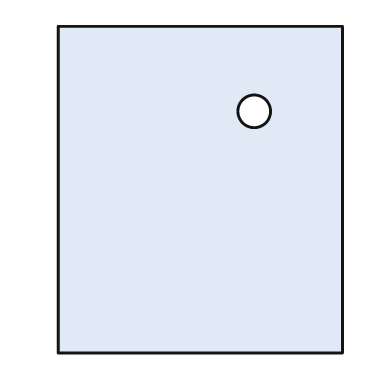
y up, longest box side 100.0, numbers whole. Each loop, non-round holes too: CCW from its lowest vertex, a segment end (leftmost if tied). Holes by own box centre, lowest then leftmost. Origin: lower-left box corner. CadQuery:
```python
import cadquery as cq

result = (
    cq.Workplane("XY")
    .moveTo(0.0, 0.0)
    .lineTo(87.0, 0.0)
    .lineTo(87.0, 100.0)
    .lineTo(0.0, 100.0)
    .close()
    .moveTo(60.0, 74.0)
    .circle(5.0)
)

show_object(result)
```